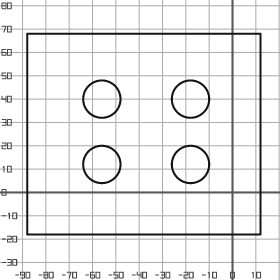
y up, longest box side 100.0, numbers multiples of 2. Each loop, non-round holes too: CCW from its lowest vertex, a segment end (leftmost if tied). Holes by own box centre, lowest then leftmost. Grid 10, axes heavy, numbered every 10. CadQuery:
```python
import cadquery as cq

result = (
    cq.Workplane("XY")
    .moveTo(-88.0, -18.0)
    .lineTo(12.0, -18.0)
    .lineTo(12.0, 68.0)
    .lineTo(-88.0, 68.0)
    .close()
    .moveTo(-56.0, 12.0)
    .circle(8.0)
    .moveTo(-18.0, 12.0)
    .circle(8.0)
    .moveTo(-56.0, 40.0)
    .circle(8.0)
    .moveTo(-18.0, 40.0)
    .circle(8.0)
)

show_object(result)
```